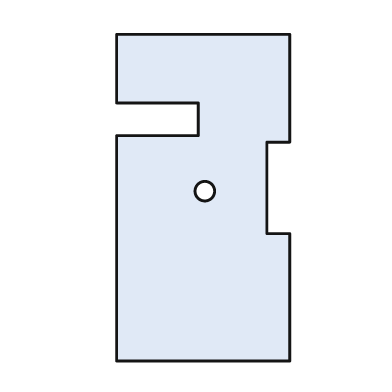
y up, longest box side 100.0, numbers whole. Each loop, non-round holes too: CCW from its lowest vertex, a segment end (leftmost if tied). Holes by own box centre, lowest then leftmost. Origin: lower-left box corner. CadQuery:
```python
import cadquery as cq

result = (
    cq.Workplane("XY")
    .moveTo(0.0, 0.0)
    .lineTo(53.0, 0.0)
    .lineTo(53.0, 39.0)
    .lineTo(46.0, 39.0)
    .lineTo(46.0, 67.0)
    .lineTo(53.0, 67.0)
    .lineTo(53.0, 100.0)
    .lineTo(0.0, 100.0)
    .lineTo(0.0, 79.0)
    .lineTo(25.0, 79.0)
    .lineTo(25.0, 69.0)
    .lineTo(0.0, 69.0)
    .close()
    .moveTo(27.0, 52.0)
    .circle(3.0)
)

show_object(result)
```